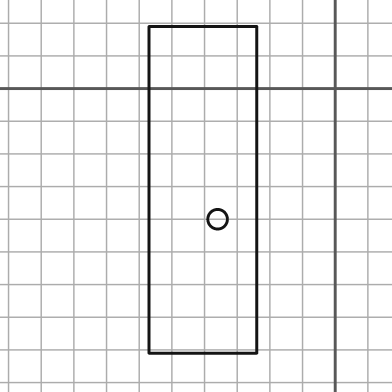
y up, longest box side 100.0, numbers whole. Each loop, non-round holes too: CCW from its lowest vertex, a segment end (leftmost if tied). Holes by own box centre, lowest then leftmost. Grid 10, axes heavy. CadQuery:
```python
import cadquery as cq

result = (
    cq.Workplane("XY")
    .moveTo(-57.0, -81.0)
    .lineTo(-24.0, -81.0)
    .lineTo(-24.0, 19.0)
    .lineTo(-57.0, 19.0)
    .close()
    .moveTo(-36.0, -40.0)
    .circle(3.0)
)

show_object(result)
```